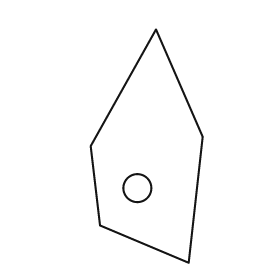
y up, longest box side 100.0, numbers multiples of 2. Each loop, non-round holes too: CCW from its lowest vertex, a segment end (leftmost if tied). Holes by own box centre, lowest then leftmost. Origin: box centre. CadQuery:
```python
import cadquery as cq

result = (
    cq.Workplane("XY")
    .moveTo(18.0, -50.0)
    .lineTo(24.0, 4.0)
    .lineTo(4.0, 50.0)
    .lineTo(-24.0, 0.0)
    .lineTo(-20.0, -34.0)
    .close()
    .moveTo(-4.0, -18.0)
    .circle(6.0)
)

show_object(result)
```